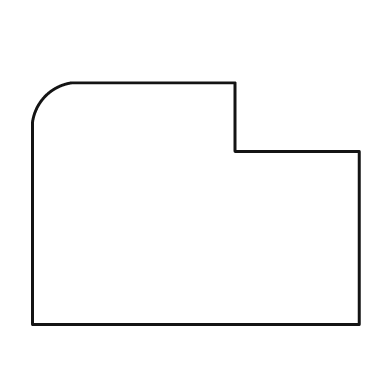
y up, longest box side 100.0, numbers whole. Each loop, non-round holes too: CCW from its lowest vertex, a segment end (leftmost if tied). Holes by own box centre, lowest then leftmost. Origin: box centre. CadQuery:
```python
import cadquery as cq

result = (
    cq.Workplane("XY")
    .moveTo(-50.0, -37.0)
    .lineTo(50.0, -37.0)
    .lineTo(50.0, 16.0)
    .lineTo(12.0, 16.0)
    .lineTo(12.0, 37.0)
    .lineTo(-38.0, 37.0)
    .threePointArc((-46.0, 33.0), (-50.0, 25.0))
    .close()
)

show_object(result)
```